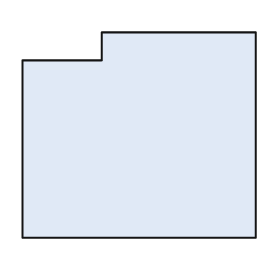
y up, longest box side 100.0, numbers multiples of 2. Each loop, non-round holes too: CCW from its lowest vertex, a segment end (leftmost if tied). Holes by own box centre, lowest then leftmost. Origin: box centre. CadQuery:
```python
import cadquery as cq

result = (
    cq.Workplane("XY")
    .moveTo(-50.0, -44.0)
    .lineTo(50.0, -44.0)
    .lineTo(50.0, 44.0)
    .lineTo(-16.0, 44.0)
    .lineTo(-16.0, 32.0)
    .lineTo(-50.0, 32.0)
    .close()
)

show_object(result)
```